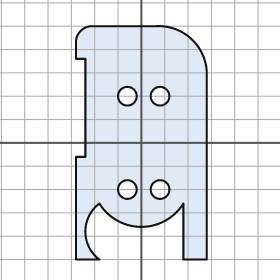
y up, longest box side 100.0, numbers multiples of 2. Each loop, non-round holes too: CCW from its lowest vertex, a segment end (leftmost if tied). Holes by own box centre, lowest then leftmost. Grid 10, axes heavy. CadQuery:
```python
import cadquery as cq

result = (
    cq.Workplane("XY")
    .moveTo(-28.0, -50.0)
    .lineTo(-18.0, -50.0)
    .threePointArc((-24.0, -38.0), (-18.0, -26.0))
    .threePointArc((0.0, -36.0), (18.0, -26.0))
    .lineTo(18.0, -50.0)
    .lineTo(28.0, -50.0)
    .lineTo(28.0, 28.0)
    .threePointArc((22.0, 44.0), (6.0, 50.0))
    .lineTo(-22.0, 50.0)
    .threePointArc((-26.0, 48.0), (-28.0, 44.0))
    .lineTo(-28.0, 36.0)
    .lineTo(-24.0, 36.0)
    .lineTo(-24.0, -6.0)
    .lineTo(-28.0, -6.0)
    .close()
    .moveTo(-6.0, -20.0)
    .circle(4.0)
    .moveTo(8.0, -20.0)
    .circle(4.0)
    .moveTo(-6.0, 20.0)
    .circle(4.0)
    .moveTo(8.0, 20.0)
    .circle(4.0)
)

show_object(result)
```